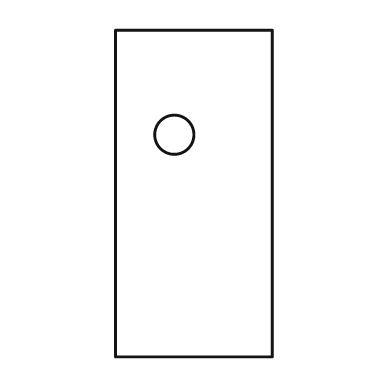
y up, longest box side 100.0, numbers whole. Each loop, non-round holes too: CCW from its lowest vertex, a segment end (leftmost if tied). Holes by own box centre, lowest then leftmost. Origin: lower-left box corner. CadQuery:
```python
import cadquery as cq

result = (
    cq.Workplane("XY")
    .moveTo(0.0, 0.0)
    .lineTo(48.0, 0.0)
    .lineTo(48.0, 100.0)
    .lineTo(0.0, 100.0)
    .close()
    .moveTo(18.0, 68.0)
    .circle(6.0)
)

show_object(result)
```